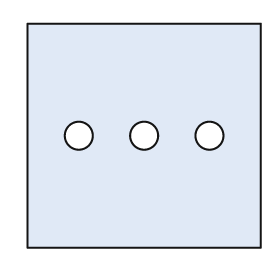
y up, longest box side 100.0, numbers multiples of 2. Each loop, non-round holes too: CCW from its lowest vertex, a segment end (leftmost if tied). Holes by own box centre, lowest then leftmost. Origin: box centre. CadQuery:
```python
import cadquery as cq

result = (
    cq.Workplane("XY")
    .moveTo(-50.0, -48.0)
    .lineTo(50.0, -48.0)
    .lineTo(50.0, 48.0)
    .lineTo(-50.0, 48.0)
    .close()
    .moveTo(-28.0, 0.0)
    .circle(6.0)
    .moveTo(0.0, 0.0)
    .circle(6.0)
    .moveTo(28.0, 0.0)
    .circle(6.0)
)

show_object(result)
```